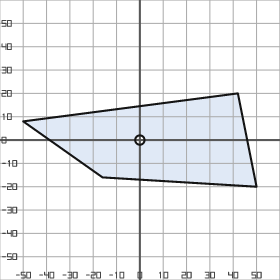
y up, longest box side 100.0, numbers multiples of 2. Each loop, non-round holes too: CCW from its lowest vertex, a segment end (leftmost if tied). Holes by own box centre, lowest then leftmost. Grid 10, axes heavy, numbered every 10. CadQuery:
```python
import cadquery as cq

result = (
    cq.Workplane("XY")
    .moveTo(50.0, -20.0)
    .lineTo(42.0, 20.0)
    .lineTo(-50.0, 8.0)
    .lineTo(-16.0, -16.0)
    .close()
    .moveTo(0.0, 0.0)
    .circle(2.0)
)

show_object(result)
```